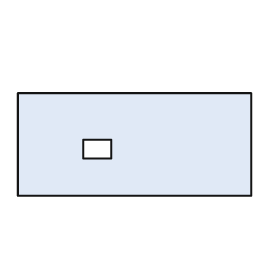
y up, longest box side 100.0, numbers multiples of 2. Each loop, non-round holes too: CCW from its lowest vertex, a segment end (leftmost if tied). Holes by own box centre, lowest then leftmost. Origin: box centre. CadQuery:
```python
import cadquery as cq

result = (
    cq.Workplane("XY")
    .moveTo(-50.0, -22.0)
    .lineTo(50.0, -22.0)
    .lineTo(50.0, 22.0)
    .lineTo(-50.0, 22.0)
    .close()
    .moveTo(-22.0, -6.0)
    .lineTo(-10.0, -6.0)
    .lineTo(-10.0, 2.0)
    .lineTo(-22.0, 2.0)
    .close()
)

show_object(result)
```